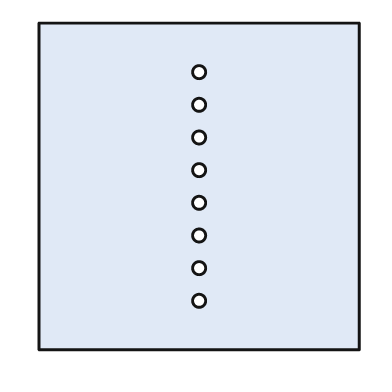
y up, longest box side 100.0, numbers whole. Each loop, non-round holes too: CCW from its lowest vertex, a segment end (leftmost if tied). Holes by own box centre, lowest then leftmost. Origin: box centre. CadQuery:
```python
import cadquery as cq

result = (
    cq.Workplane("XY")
    .moveTo(-49.0, -50.0)
    .lineTo(49.0, -50.0)
    .lineTo(49.0, 50.0)
    .lineTo(-49.0, 50.0)
    .close()
    .moveTo(0.0, -35.0)
    .circle(2.0)
    .moveTo(0.0, -25.0)
    .circle(2.0)
    .moveTo(0.0, -15.0)
    .circle(2.0)
    .moveTo(0.0, -5.0)
    .circle(2.0)
    .moveTo(0.0, 5.0)
    .circle(2.0)
    .moveTo(0.0, 15.0)
    .circle(2.0)
    .moveTo(0.0, 25.0)
    .circle(2.0)
    .moveTo(0.0, 35.0)
    .circle(2.0)
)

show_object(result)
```